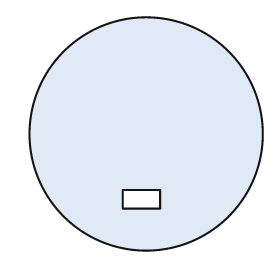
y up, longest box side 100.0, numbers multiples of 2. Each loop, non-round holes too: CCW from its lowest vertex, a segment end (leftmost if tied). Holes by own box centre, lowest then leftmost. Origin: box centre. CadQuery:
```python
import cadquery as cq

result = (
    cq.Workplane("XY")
    .moveTo(0.0, 0.0)
    .circle(50.0)
    .moveTo(-10.0, -32.0)
    .lineTo(6.0, -32.0)
    .lineTo(6.0, -24.0)
    .lineTo(-10.0, -24.0)
    .close()
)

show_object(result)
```